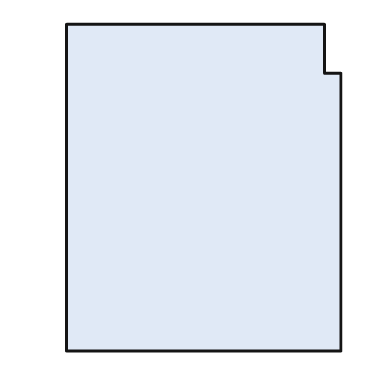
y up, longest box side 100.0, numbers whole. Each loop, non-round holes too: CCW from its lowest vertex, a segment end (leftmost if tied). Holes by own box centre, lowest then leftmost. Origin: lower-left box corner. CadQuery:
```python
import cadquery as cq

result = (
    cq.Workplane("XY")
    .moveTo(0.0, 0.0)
    .lineTo(84.0, 0.0)
    .lineTo(84.0, 85.0)
    .lineTo(79.0, 85.0)
    .lineTo(79.0, 100.0)
    .lineTo(0.0, 100.0)
    .close()
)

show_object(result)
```